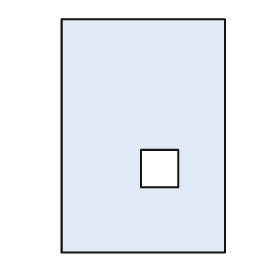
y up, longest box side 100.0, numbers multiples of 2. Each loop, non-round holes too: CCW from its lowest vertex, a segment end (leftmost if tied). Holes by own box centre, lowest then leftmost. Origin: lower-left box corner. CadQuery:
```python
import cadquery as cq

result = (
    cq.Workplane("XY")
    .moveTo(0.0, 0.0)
    .lineTo(70.0, 0.0)
    .lineTo(70.0, 100.0)
    .lineTo(0.0, 100.0)
    .close()
    .moveTo(34.0, 28.0)
    .lineTo(50.0, 28.0)
    .lineTo(50.0, 44.0)
    .lineTo(34.0, 44.0)
    .close()
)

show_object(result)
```